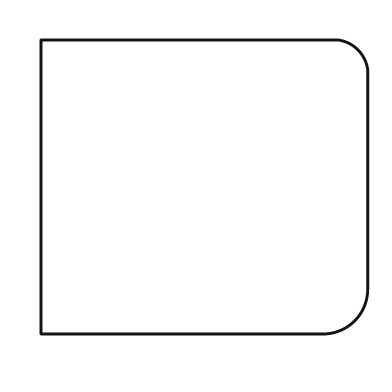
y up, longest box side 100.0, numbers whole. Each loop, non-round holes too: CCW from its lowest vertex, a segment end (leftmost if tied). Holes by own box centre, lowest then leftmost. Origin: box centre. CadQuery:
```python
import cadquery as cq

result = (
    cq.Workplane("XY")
    .moveTo(-50.0, -45.0)
    .lineTo(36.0, -45.0)
    .threePointArc((46.0, -41.0), (50.0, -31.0))
    .lineTo(50.0, 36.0)
    .threePointArc((47.0, 42.0), (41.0, 45.0))
    .lineTo(-50.0, 45.0)
    .close()
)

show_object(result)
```